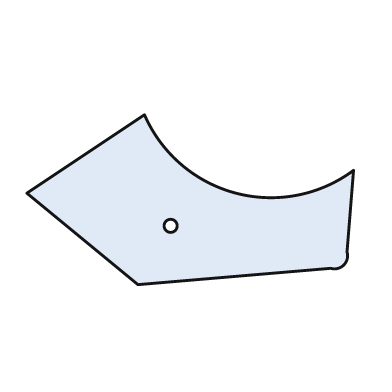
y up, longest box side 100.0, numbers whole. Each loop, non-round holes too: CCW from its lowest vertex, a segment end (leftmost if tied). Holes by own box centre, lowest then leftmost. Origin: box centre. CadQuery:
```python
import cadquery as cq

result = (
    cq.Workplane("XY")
    .moveTo(-16.0, -26.0)
    .lineTo(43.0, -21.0)
    .threePointArc((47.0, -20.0), (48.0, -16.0))
    .lineTo(50.0, 9.0)
    .threePointArc((14.0, 2.0), (-14.0, 26.0))
    .lineTo(-50.0, 2.0)
    .close()
    .moveTo(-6.0, -8.0)
    .circle(2.0)
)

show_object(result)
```